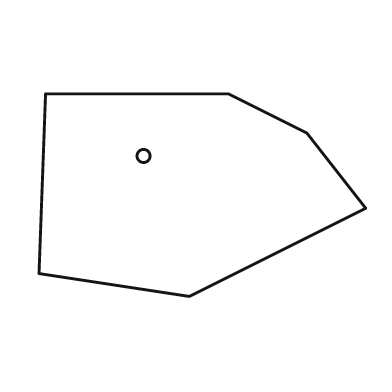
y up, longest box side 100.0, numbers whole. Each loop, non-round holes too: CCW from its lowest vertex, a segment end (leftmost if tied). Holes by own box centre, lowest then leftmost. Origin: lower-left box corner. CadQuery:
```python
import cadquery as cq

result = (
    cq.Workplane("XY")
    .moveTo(46.0, 0.0)
    .lineTo(100.0, 27.0)
    .lineTo(82.0, 50.0)
    .lineTo(58.0, 62.0)
    .lineTo(2.0, 62.0)
    .lineTo(0.0, 7.0)
    .close()
    .moveTo(32.0, 43.0)
    .circle(2.0)
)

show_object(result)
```